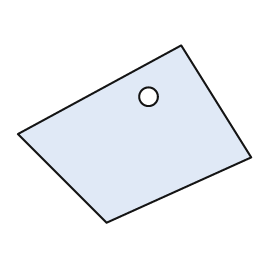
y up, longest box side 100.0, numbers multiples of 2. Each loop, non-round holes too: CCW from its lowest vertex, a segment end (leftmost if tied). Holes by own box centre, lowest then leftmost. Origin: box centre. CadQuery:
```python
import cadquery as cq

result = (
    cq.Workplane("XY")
    .moveTo(-12.0, -38.0)
    .lineTo(50.0, -10.0)
    .lineTo(20.0, 38.0)
    .lineTo(-50.0, 0.0)
    .close()
    .moveTo(6.0, 16.0)
    .circle(4.0)
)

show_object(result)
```